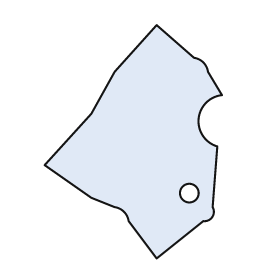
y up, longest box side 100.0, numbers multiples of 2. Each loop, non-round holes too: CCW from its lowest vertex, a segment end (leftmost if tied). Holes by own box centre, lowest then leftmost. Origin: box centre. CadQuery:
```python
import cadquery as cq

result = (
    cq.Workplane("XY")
    .moveTo(10.0, -50.0)
    .lineTo(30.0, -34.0)
    .threePointArc((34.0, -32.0), (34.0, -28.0))
    .lineTo(36.0, -2.0)
    .threePointArc((28.0, 10.0), (38.0, 20.0))
    .lineTo(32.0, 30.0)
    .threePointArc((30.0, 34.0), (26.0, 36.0))
    .lineTo(10.0, 50.0)
    .lineTo(-8.0, 30.0)
    .lineTo(-18.0, 12.0)
    .lineTo(-38.0, -10.0)
    .lineTo(-18.0, -24.0)
    .lineTo(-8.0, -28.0)
    .threePointArc((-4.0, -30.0), (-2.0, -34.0))
    .close()
    .moveTo(24.0, -22.0)
    .circle(4.0)
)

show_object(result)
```